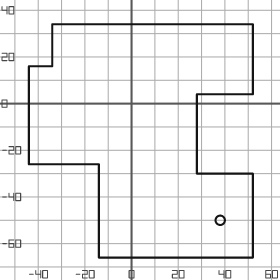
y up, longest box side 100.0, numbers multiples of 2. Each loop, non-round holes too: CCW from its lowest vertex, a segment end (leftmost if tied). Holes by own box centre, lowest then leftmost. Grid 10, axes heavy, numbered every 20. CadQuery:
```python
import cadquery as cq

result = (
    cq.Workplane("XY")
    .moveTo(-14.0, -66.0)
    .lineTo(52.0, -66.0)
    .lineTo(52.0, -30.0)
    .lineTo(28.0, -30.0)
    .lineTo(28.0, 4.0)
    .lineTo(52.0, 4.0)
    .lineTo(52.0, 34.0)
    .lineTo(-34.0, 34.0)
    .lineTo(-34.0, 16.0)
    .lineTo(-44.0, 16.0)
    .lineTo(-44.0, -26.0)
    .lineTo(-14.0, -26.0)
    .close()
    .moveTo(38.0, -50.0)
    .circle(2.0)
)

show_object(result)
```